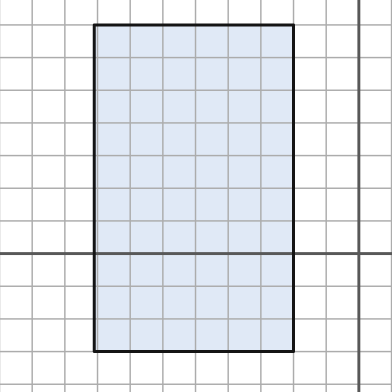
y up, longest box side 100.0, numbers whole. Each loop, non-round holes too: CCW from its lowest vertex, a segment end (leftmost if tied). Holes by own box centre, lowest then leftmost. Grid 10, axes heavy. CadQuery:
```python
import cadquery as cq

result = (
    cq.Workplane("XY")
    .moveTo(-81.0, -30.0)
    .lineTo(-20.0, -30.0)
    .lineTo(-20.0, 70.0)
    .lineTo(-81.0, 70.0)
    .close()
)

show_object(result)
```